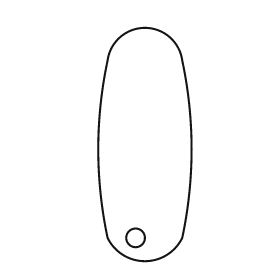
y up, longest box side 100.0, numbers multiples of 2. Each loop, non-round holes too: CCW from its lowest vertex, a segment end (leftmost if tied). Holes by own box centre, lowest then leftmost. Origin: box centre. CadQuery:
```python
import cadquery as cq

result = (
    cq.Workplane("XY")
    .moveTo(-16.0, -40.0)
    .threePointArc((0.0, -50.0), (16.0, -40.0))
    .threePointArc((20.0, -2.0), (16.0, 36.0))
    .threePointArc((0.0, 50.0), (-16.0, 36.0))
    .threePointArc((-20.0, -2.0), (-16.0, -40.0))
    .close()
    .moveTo(-4.0, -40.0)
    .circle(4.0)
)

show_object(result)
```